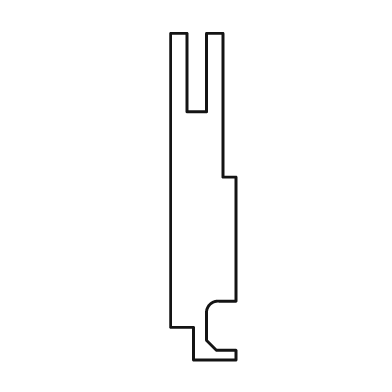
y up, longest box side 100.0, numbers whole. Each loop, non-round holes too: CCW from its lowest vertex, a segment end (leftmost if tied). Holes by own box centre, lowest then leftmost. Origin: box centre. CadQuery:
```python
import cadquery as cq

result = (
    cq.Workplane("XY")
    .moveTo(-3.0, -50.0)
    .lineTo(10.0, -50.0)
    .lineTo(10.0, -47.0)
    .lineTo(4.0, -47.0)
    .lineTo(1.0, -44.0)
    .lineTo(1.0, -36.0)
    .threePointArc((2.0, -33.0), (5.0, -32.0))
    .lineTo(10.0, -32.0)
    .lineTo(10.0, 6.0)
    .lineTo(6.0, 6.0)
    .lineTo(6.0, 50.0)
    .lineTo(1.0, 50.0)
    .lineTo(1.0, 26.0)
    .lineTo(-5.0, 26.0)
    .lineTo(-5.0, 50.0)
    .lineTo(-10.0, 50.0)
    .lineTo(-10.0, -40.0)
    .lineTo(-3.0, -40.0)
    .close()
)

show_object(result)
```